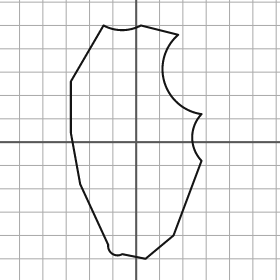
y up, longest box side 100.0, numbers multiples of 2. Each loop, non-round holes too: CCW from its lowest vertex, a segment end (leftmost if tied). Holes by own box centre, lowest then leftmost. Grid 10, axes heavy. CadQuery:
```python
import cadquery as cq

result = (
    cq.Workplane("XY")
    .moveTo(4.0, -50.0)
    .lineTo(16.0, -40.0)
    .lineTo(28.0, -8.0)
    .threePointArc((24.0, 2.0), (28.0, 12.0))
    .threePointArc((12.0, 26.0), (18.0, 46.0))
    .lineTo(2.0, 50.0)
    .threePointArc((-6.0, 48.0), (-14.0, 50.0))
    .lineTo(-28.0, 26.0)
    .lineTo(-28.0, 4.0)
    .lineTo(-24.0, -18.0)
    .lineTo(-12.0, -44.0)
    .threePointArc((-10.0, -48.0), (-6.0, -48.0))
    .close()
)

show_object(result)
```